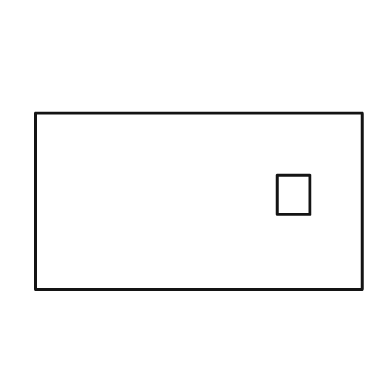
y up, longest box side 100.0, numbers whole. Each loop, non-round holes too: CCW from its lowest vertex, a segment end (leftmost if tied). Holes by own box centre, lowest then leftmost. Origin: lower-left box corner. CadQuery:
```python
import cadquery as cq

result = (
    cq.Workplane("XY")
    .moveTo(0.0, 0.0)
    .lineTo(100.0, 0.0)
    .lineTo(100.0, 54.0)
    .lineTo(0.0, 54.0)
    .close()
    .moveTo(74.0, 23.0)
    .lineTo(84.0, 23.0)
    .lineTo(84.0, 35.0)
    .lineTo(74.0, 35.0)
    .close()
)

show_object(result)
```